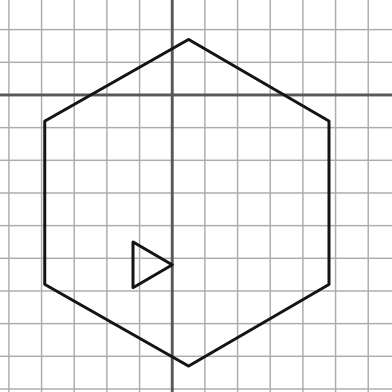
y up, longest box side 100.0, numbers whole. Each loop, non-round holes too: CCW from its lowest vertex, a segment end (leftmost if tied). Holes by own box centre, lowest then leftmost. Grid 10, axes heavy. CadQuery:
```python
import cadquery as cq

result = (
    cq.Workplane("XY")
    .moveTo(5.0, -83.0)
    .lineTo(48.0, -58.0)
    .lineTo(48.0, -8.0)
    .lineTo(5.0, 17.0)
    .lineTo(-39.0, -8.0)
    .lineTo(-39.0, -58.0)
    .close()
    .moveTo(-12.0, -59.0)
    .lineTo(0.0, -52.0)
    .lineTo(-12.0, -45.0)
    .close()
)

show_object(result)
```